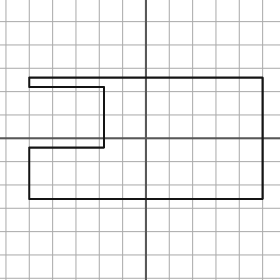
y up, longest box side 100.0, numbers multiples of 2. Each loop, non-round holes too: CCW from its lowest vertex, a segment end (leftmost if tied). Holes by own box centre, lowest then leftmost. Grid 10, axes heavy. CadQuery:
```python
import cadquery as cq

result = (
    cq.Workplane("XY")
    .moveTo(-50.0, -26.0)
    .lineTo(50.0, -26.0)
    .lineTo(50.0, 26.0)
    .lineTo(-50.0, 26.0)
    .lineTo(-50.0, 22.0)
    .lineTo(-18.0, 22.0)
    .lineTo(-18.0, -4.0)
    .lineTo(-50.0, -4.0)
    .close()
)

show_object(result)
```